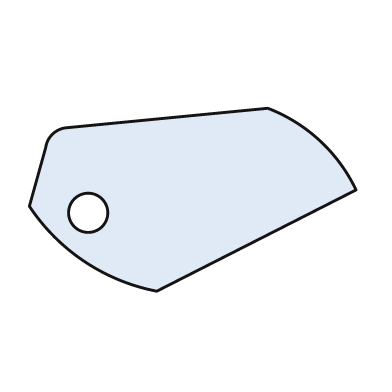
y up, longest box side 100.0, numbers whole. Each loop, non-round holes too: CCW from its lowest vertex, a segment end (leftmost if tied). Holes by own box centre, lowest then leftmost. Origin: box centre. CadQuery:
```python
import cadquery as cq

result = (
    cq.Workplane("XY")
    .moveTo(-11.0, -28.0)
    .lineTo(50.0, 3.0)
    .threePointArc((39.0, 18.0), (23.0, 28.0))
    .lineTo(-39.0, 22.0)
    .threePointArc((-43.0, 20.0), (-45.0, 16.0))
    .lineTo(-50.0, -2.0)
    .threePointArc((-33.0, -19.0), (-11.0, -28.0))
    .close()
    .moveTo(-32.0, -4.0)
    .circle(6.0)
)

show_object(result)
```